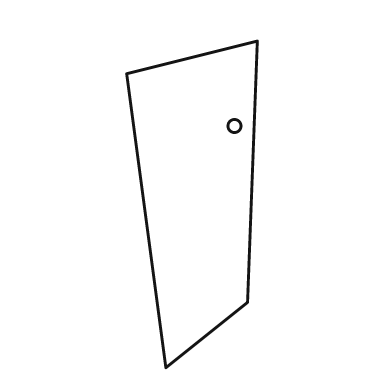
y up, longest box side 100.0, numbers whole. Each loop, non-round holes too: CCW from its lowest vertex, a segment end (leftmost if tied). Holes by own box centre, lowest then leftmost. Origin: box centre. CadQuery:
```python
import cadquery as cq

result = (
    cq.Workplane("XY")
    .moveTo(-8.0, -50.0)
    .lineTo(17.0, -30.0)
    .lineTo(20.0, 50.0)
    .lineTo(-20.0, 40.0)
    .close()
    .moveTo(13.0, 24.0)
    .circle(2.0)
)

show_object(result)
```